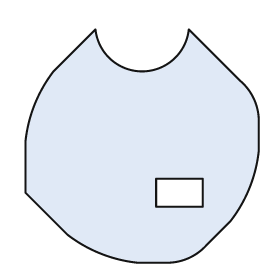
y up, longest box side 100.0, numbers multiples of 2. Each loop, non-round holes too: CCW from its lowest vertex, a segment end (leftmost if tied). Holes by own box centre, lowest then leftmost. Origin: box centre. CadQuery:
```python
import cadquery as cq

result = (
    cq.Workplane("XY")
    .moveTo(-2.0, -50.0)
    .lineTo(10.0, -50.0)
    .threePointArc((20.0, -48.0), (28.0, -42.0))
    .lineTo(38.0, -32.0)
    .threePointArc((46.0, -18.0), (50.0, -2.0))
    .lineTo(50.0, 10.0)
    .threePointArc((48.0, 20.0), (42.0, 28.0))
    .lineTo(20.0, 50.0)
    .threePointArc((0.0, 32.0), (-20.0, 50.0))
    .lineTo(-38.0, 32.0)
    .threePointArc((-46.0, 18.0), (-50.0, 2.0))
    .lineTo(-50.0, -20.0)
    .lineTo(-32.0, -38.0)
    .threePointArc((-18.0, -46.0), (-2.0, -50.0))
    .close()
    .moveTo(6.0, -26.0)
    .lineTo(26.0, -26.0)
    .lineTo(26.0, -14.0)
    .lineTo(6.0, -14.0)
    .close()
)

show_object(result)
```